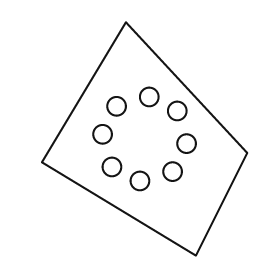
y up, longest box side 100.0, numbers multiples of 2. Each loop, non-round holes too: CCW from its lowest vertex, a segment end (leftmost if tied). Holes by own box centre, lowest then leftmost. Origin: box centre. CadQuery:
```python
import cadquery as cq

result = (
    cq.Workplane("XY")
    .moveTo(22.0, -50.0)
    .lineTo(44.0, -6.0)
    .lineTo(-8.0, 50.0)
    .lineTo(-44.0, -10.0)
    .close()
    .moveTo(-2.0, -18.0)
    .circle(4.0)
    .moveTo(12.0, -14.0)
    .circle(4.0)
    .moveTo(-14.0, -12.0)
    .circle(4.0)
    .moveTo(18.0, -2.0)
    .circle(4.0)
    .moveTo(-18.0, 2.0)
    .circle(4.0)
    .moveTo(14.0, 12.0)
    .circle(4.0)
    .moveTo(-12.0, 14.0)
    .circle(4.0)
    .moveTo(2.0, 18.0)
    .circle(4.0)
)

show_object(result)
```